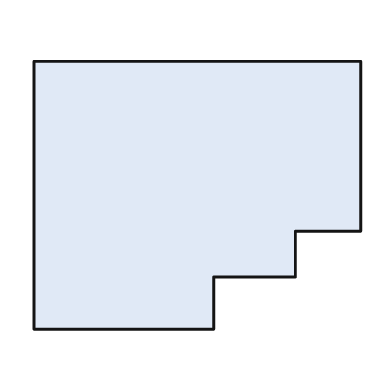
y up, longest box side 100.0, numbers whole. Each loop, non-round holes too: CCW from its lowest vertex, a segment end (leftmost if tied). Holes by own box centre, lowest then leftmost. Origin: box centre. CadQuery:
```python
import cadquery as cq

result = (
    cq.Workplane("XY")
    .moveTo(-50.0, -41.0)
    .lineTo(5.0, -41.0)
    .lineTo(5.0, -25.0)
    .lineTo(30.0, -25.0)
    .lineTo(30.0, -11.0)
    .lineTo(50.0, -11.0)
    .lineTo(50.0, 41.0)
    .lineTo(-50.0, 41.0)
    .close()
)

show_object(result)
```